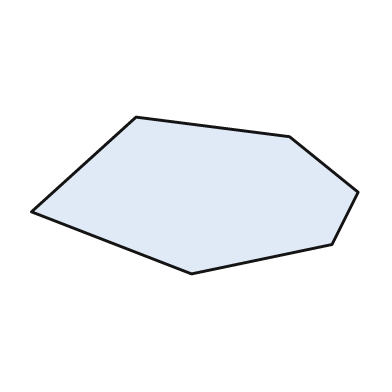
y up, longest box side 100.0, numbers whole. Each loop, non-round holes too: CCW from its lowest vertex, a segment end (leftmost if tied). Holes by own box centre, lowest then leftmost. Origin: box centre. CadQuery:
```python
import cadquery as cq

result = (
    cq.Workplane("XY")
    .moveTo(-1.0, -24.0)
    .lineTo(42.0, -15.0)
    .lineTo(50.0, 1.0)
    .lineTo(29.0, 18.0)
    .lineTo(-18.0, 24.0)
    .lineTo(-50.0, -5.0)
    .close()
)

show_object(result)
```